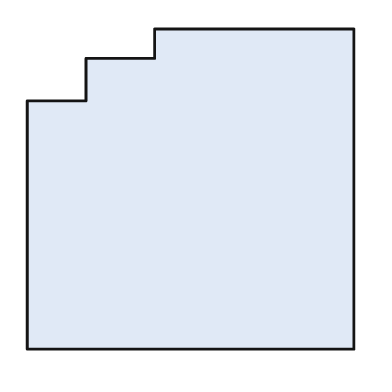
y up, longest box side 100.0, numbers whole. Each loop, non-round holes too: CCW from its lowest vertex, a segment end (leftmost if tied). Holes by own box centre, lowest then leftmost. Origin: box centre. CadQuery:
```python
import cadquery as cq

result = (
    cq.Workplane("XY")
    .moveTo(-50.0, -49.0)
    .lineTo(50.0, -49.0)
    .lineTo(50.0, 49.0)
    .lineTo(-11.0, 49.0)
    .lineTo(-11.0, 40.0)
    .lineTo(-32.0, 40.0)
    .lineTo(-32.0, 27.0)
    .lineTo(-50.0, 27.0)
    .close()
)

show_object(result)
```